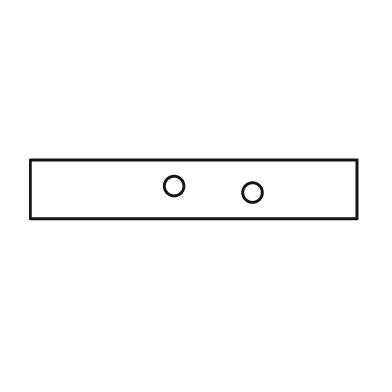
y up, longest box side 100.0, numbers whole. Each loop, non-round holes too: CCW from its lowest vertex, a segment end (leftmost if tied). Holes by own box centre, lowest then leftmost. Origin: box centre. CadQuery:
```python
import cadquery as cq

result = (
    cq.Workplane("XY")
    .moveTo(-50.0, -9.0)
    .lineTo(50.0, -9.0)
    .lineTo(50.0, 9.0)
    .lineTo(-50.0, 9.0)
    .close()
    .moveTo(18.0, -1.0)
    .circle(3.0)
    .moveTo(-6.0, 1.0)
    .circle(3.0)
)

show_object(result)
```